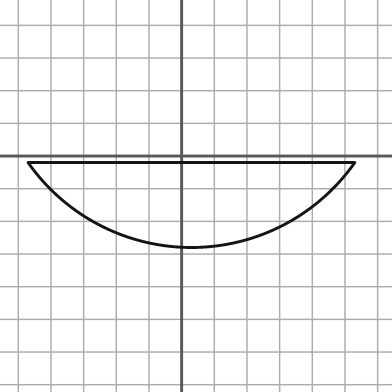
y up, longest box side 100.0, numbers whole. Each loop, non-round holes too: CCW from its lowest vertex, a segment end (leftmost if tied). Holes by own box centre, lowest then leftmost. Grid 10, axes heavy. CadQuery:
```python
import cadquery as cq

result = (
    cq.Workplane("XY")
    .moveTo(-47.0, -2.0)
    .threePointArc((3.0, -28.0), (53.0, -2.0))
    .close()
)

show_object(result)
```